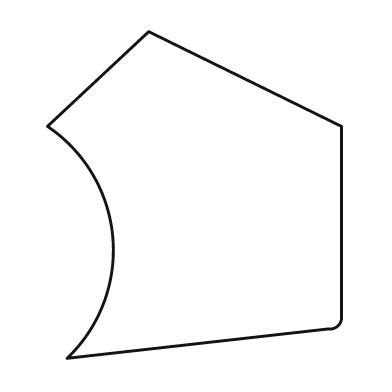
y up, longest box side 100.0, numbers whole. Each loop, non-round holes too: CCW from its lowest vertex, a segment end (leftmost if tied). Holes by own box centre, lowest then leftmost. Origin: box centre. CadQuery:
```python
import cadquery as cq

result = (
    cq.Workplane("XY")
    .moveTo(-39.0, -50.0)
    .lineTo(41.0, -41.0)
    .threePointArc((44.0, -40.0), (45.0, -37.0))
    .lineTo(45.0, 21.0)
    .lineTo(-14.0, 50.0)
    .lineTo(-45.0, 21.0)
    .threePointArc((-25.0, -13.0), (-39.0, -50.0))
    .close()
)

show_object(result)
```